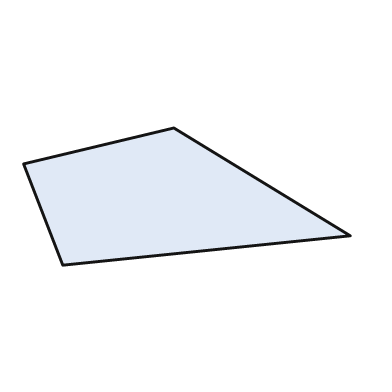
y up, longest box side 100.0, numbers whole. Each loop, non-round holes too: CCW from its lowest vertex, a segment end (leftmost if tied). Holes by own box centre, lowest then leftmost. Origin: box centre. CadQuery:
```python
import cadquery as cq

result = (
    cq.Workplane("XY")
    .moveTo(-38.0, -21.0)
    .lineTo(50.0, -12.0)
    .lineTo(-4.0, 21.0)
    .lineTo(-50.0, 10.0)
    .close()
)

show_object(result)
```